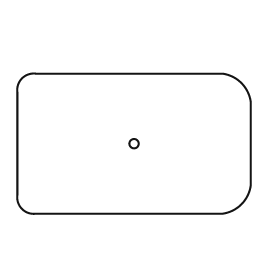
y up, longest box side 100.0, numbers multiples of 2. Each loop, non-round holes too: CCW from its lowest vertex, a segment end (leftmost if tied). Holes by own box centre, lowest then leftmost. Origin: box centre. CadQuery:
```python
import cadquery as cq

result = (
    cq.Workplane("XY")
    .moveTo(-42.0, -30.0)
    .lineTo(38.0, -30.0)
    .threePointArc((46.0, -26.0), (50.0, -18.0))
    .lineTo(50.0, 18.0)
    .threePointArc((46.0, 26.0), (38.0, 30.0))
    .lineTo(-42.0, 30.0)
    .threePointArc((-48.0, 28.0), (-50.0, 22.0))
    .lineTo(-50.0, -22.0)
    .threePointArc((-48.0, -28.0), (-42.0, -30.0))
    .close()
    .moveTo(0.0, 0.0)
    .circle(2.0)
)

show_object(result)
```